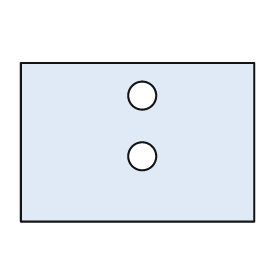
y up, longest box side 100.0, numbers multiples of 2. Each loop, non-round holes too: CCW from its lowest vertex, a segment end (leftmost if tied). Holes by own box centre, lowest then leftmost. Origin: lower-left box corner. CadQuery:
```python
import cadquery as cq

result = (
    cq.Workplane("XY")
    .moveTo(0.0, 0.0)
    .lineTo(100.0, 0.0)
    .lineTo(100.0, 68.0)
    .lineTo(0.0, 68.0)
    .close()
    .moveTo(52.0, 28.0)
    .circle(6.0)
    .moveTo(52.0, 54.0)
    .circle(6.0)
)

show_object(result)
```